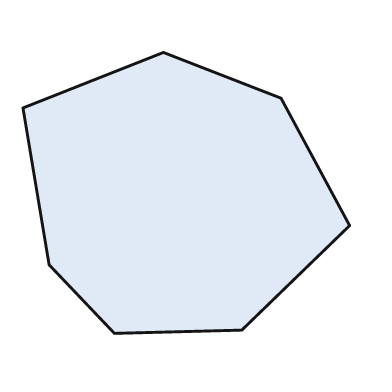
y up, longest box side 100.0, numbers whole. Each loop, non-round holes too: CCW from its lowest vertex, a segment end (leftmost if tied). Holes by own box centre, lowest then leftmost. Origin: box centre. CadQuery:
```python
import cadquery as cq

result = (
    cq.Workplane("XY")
    .moveTo(-22.0, -43.0)
    .lineTo(17.0, -42.0)
    .lineTo(50.0, -10.0)
    .lineTo(29.0, 29.0)
    .lineTo(-7.0, 43.0)
    .lineTo(-50.0, 26.0)
    .lineTo(-42.0, -22.0)
    .close()
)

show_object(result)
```